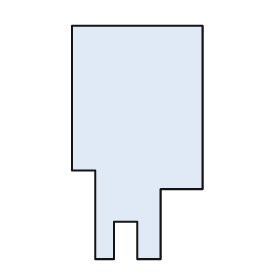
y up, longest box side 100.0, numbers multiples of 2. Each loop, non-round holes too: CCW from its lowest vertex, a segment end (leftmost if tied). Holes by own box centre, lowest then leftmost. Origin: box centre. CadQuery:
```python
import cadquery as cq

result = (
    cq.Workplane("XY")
    .moveTo(-18.0, -50.0)
    .lineTo(-10.0, -50.0)
    .lineTo(-10.0, -34.0)
    .lineTo(0.0, -34.0)
    .lineTo(0.0, -50.0)
    .lineTo(10.0, -50.0)
    .lineTo(10.0, -20.0)
    .lineTo(28.0, -20.0)
    .lineTo(28.0, 50.0)
    .lineTo(-28.0, 50.0)
    .lineTo(-28.0, -12.0)
    .lineTo(-18.0, -12.0)
    .close()
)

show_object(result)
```